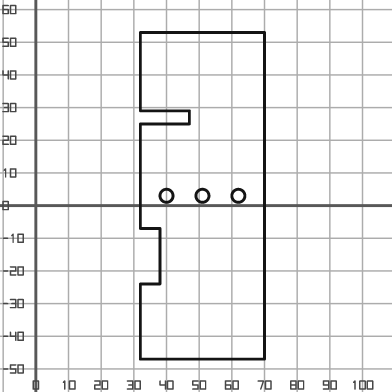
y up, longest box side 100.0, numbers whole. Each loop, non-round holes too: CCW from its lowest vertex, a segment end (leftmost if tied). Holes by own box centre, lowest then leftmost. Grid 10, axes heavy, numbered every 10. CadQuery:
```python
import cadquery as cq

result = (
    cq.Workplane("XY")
    .moveTo(32.0, -47.0)
    .lineTo(70.0, -47.0)
    .lineTo(70.0, 53.0)
    .lineTo(32.0, 53.0)
    .lineTo(32.0, 29.0)
    .lineTo(47.0, 29.0)
    .lineTo(47.0, 25.0)
    .lineTo(32.0, 25.0)
    .lineTo(32.0, -7.0)
    .lineTo(38.0, -7.0)
    .lineTo(38.0, -24.0)
    .lineTo(32.0, -24.0)
    .close()
    .moveTo(40.0, 3.0)
    .circle(2.0)
    .moveTo(51.0, 3.0)
    .circle(2.0)
    .moveTo(62.0, 3.0)
    .circle(2.0)
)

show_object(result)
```